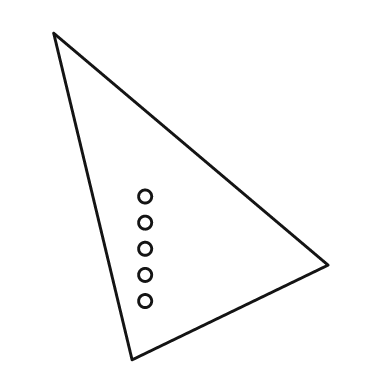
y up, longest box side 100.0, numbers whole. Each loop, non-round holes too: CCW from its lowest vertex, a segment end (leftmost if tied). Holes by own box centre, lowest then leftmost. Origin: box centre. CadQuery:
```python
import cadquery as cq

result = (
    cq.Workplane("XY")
    .moveTo(-18.0, -50.0)
    .lineTo(42.0, -21.0)
    .lineTo(-42.0, 50.0)
    .close()
    .moveTo(-14.0, -32.0)
    .circle(2.0)
    .moveTo(-14.0, -24.0)
    .circle(2.0)
    .moveTo(-14.0, -16.0)
    .circle(2.0)
    .moveTo(-14.0, -8.0)
    .circle(2.0)
    .moveTo(-14.0, 0.0)
    .circle(2.0)
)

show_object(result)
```